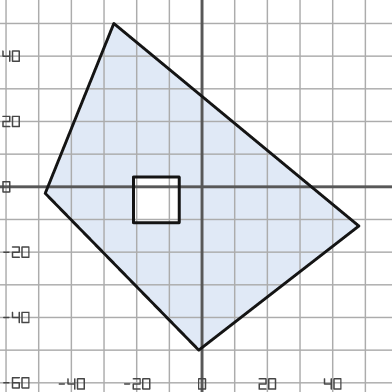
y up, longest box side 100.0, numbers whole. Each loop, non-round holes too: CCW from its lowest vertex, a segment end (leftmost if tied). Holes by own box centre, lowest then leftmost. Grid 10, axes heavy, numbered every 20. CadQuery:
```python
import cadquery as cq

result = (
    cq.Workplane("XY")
    .moveTo(-1.0, -50.0)
    .lineTo(48.0, -12.0)
    .lineTo(-27.0, 50.0)
    .lineTo(-48.0, -2.0)
    .close()
    .moveTo(-21.0, -11.0)
    .lineTo(-7.0, -11.0)
    .lineTo(-7.0, 3.0)
    .lineTo(-21.0, 3.0)
    .close()
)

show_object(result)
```